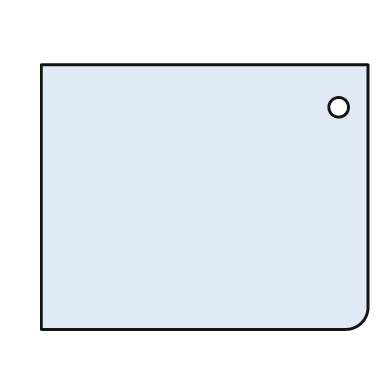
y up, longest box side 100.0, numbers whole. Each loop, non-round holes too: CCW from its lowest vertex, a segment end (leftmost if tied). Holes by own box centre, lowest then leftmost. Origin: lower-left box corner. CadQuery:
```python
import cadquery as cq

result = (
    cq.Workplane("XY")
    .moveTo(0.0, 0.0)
    .lineTo(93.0, 0.0)
    .threePointArc((98.0, 2.0), (100.0, 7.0))
    .lineTo(100.0, 81.0)
    .lineTo(0.0, 81.0)
    .close()
    .moveTo(91.0, 68.0)
    .circle(3.0)
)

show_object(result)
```